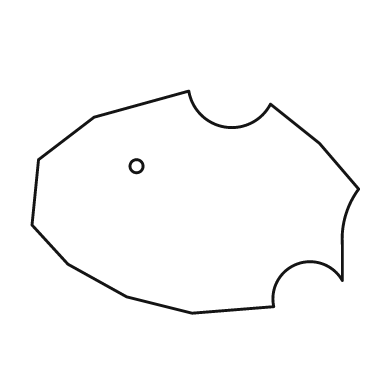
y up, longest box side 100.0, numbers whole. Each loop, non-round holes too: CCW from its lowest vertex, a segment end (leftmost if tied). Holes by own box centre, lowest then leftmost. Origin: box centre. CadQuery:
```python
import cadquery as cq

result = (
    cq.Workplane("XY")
    .moveTo(-1.0, -34.0)
    .lineTo(24.0, -32.0)
    .threePointArc((31.0, -19.0), (45.0, -24.0))
    .lineTo(45.0, -13.0)
    .threePointArc((46.0, -4.0), (50.0, 4.0))
    .lineTo(38.0, 18.0)
    .lineTo(23.0, 30.0)
    .threePointArc((9.0, 23.0), (-2.0, 34.0))
    .lineTo(-31.0, 26.0)
    .lineTo(-48.0, 13.0)
    .lineTo(-50.0, -7.0)
    .lineTo(-39.0, -19.0)
    .lineTo(-21.0, -29.0)
    .close()
    .moveTo(-18.0, 11.0)
    .circle(2.0)
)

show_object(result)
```